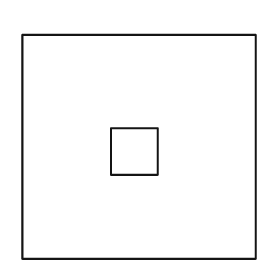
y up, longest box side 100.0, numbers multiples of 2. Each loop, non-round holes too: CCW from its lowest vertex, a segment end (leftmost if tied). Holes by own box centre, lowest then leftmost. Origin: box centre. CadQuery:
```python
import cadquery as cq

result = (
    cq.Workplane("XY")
    .moveTo(-50.0, -48.0)
    .lineTo(50.0, -48.0)
    .lineTo(50.0, 48.0)
    .lineTo(-50.0, 48.0)
    .close()
    .moveTo(-12.0, -12.0)
    .lineTo(8.0, -12.0)
    .lineTo(8.0, 8.0)
    .lineTo(-12.0, 8.0)
    .close()
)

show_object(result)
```